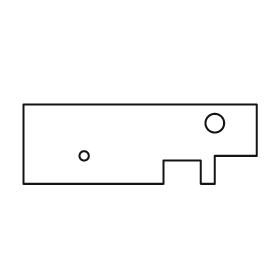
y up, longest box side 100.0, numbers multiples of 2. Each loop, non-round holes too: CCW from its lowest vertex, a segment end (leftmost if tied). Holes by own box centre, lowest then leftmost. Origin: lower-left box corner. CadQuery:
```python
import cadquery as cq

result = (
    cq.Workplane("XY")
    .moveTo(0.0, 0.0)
    .lineTo(60.0, 0.0)
    .lineTo(60.0, 10.0)
    .lineTo(76.0, 10.0)
    .lineTo(76.0, 0.0)
    .lineTo(82.0, 0.0)
    .lineTo(82.0, 12.0)
    .lineTo(100.0, 12.0)
    .lineTo(100.0, 34.0)
    .lineTo(0.0, 34.0)
    .close()
    .moveTo(26.0, 12.0)
    .circle(2.0)
    .moveTo(82.0, 26.0)
    .circle(4.0)
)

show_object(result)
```